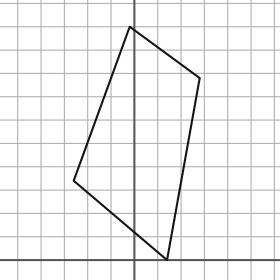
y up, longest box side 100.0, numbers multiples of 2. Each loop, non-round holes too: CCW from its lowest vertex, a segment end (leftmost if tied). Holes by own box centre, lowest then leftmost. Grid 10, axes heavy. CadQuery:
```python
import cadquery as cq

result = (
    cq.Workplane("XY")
    .moveTo(14.0, 0.0)
    .lineTo(28.0, 78.0)
    .lineTo(-2.0, 100.0)
    .lineTo(-26.0, 34.0)
    .close()
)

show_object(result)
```